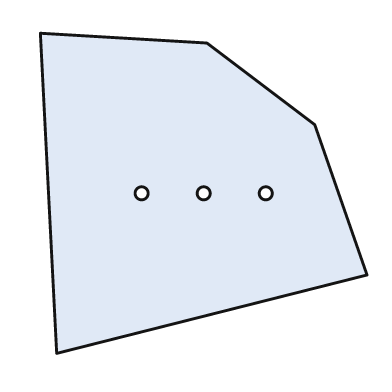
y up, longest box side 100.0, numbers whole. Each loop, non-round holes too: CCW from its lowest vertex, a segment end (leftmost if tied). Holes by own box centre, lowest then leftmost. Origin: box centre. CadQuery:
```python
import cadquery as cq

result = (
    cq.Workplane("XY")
    .moveTo(-45.0, -49.0)
    .lineTo(50.0, -25.0)
    .lineTo(34.0, 21.0)
    .lineTo(1.0, 46.0)
    .lineTo(-50.0, 49.0)
    .close()
    .moveTo(-19.0, 0.0)
    .circle(2.0)
    .moveTo(0.0, 0.0)
    .circle(2.0)
    .moveTo(19.0, 0.0)
    .circle(2.0)
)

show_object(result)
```